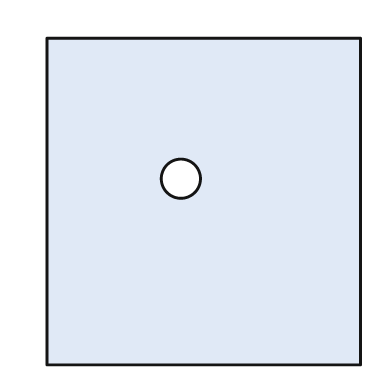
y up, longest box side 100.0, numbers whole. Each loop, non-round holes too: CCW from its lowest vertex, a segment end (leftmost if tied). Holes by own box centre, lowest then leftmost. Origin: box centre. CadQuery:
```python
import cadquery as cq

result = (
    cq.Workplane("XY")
    .moveTo(-48.0, -50.0)
    .lineTo(48.0, -50.0)
    .lineTo(48.0, 50.0)
    .lineTo(-48.0, 50.0)
    .close()
    .moveTo(-7.0, 7.0)
    .circle(6.0)
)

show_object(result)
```